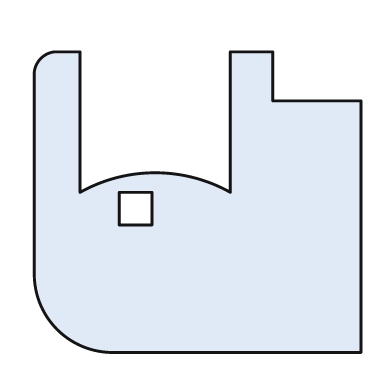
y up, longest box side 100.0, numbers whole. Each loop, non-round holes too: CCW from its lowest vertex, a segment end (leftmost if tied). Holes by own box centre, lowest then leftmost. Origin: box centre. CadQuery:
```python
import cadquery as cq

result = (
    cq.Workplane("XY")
    .moveTo(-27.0, -46.0)
    .lineTo(50.0, -46.0)
    .lineTo(50.0, 31.0)
    .lineTo(23.0, 31.0)
    .lineTo(23.0, 46.0)
    .lineTo(10.0, 46.0)
    .lineTo(10.0, 3.0)
    .threePointArc((-13.0, 9.0), (-36.0, 3.0))
    .lineTo(-36.0, 46.0)
    .lineTo(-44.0, 46.0)
    .threePointArc((-48.0, 44.0), (-50.0, 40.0))
    .lineTo(-50.0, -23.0)
    .threePointArc((-43.0, -39.0), (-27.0, -46.0))
    .close()
    .moveTo(-24.0, -7.0)
    .lineTo(-14.0, -7.0)
    .lineTo(-14.0, 3.0)
    .lineTo(-24.0, 3.0)
    .close()
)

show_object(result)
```